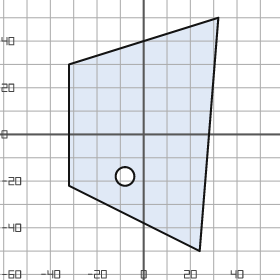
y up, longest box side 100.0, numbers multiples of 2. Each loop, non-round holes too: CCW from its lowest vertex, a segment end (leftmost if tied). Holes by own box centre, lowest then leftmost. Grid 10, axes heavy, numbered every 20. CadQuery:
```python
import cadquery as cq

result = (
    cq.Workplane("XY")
    .moveTo(24.0, -50.0)
    .lineTo(32.0, 50.0)
    .lineTo(-32.0, 30.0)
    .lineTo(-32.0, -22.0)
    .close()
    .moveTo(-8.0, -18.0)
    .circle(4.0)
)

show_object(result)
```